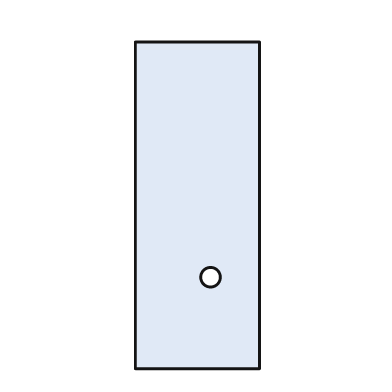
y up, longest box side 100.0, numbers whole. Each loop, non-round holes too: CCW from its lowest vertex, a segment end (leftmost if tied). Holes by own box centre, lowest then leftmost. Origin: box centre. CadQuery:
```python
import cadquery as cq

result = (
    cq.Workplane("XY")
    .moveTo(-19.0, -50.0)
    .lineTo(19.0, -50.0)
    .lineTo(19.0, 50.0)
    .lineTo(-19.0, 50.0)
    .close()
    .moveTo(4.0, -22.0)
    .circle(3.0)
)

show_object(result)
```